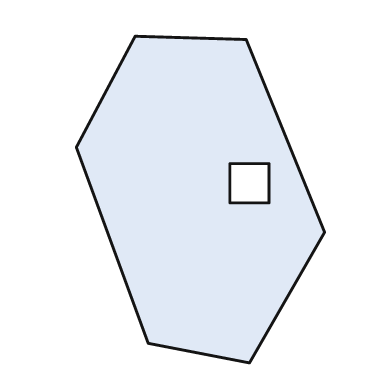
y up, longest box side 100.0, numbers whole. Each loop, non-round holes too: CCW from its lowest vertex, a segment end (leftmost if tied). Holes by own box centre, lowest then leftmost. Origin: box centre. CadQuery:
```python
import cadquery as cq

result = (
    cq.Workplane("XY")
    .moveTo(15.0, -50.0)
    .lineTo(38.0, -10.0)
    .lineTo(14.0, 49.0)
    .lineTo(-20.0, 50.0)
    .lineTo(-38.0, 16.0)
    .lineTo(-16.0, -44.0)
    .close()
    .moveTo(9.0, -1.0)
    .lineTo(21.0, -1.0)
    .lineTo(21.0, 11.0)
    .lineTo(9.0, 11.0)
    .close()
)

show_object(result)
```